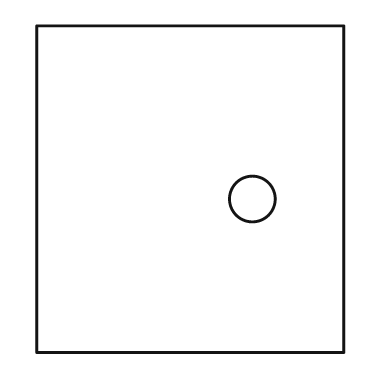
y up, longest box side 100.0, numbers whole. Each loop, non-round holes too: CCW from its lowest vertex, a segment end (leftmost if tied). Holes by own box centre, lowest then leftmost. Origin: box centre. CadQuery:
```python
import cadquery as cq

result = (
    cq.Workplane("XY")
    .moveTo(-47.0, -50.0)
    .lineTo(47.0, -50.0)
    .lineTo(47.0, 50.0)
    .lineTo(-47.0, 50.0)
    .close()
    .moveTo(19.0, -3.0)
    .circle(7.0)
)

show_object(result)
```